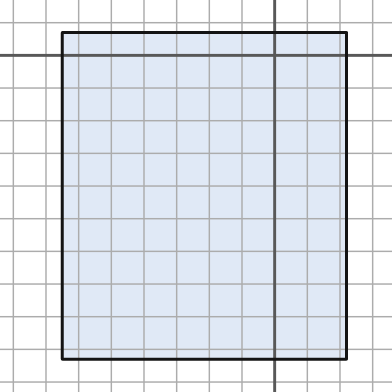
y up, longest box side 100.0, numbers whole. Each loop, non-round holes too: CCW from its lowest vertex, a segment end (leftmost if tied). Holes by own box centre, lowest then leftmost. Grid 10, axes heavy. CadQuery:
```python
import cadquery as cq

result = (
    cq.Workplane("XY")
    .moveTo(-65.0, -93.0)
    .lineTo(22.0, -93.0)
    .lineTo(22.0, 7.0)
    .lineTo(-65.0, 7.0)
    .close()
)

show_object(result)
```